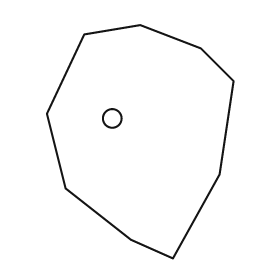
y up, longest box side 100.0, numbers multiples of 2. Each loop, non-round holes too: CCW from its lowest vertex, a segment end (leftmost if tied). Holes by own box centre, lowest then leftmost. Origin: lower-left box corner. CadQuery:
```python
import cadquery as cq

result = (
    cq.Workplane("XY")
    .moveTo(54.0, 0.0)
    .lineTo(74.0, 36.0)
    .lineTo(80.0, 76.0)
    .lineTo(66.0, 90.0)
    .lineTo(40.0, 100.0)
    .lineTo(16.0, 96.0)
    .lineTo(0.0, 62.0)
    .lineTo(8.0, 30.0)
    .lineTo(36.0, 8.0)
    .close()
    .moveTo(28.0, 60.0)
    .circle(4.0)
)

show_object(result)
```